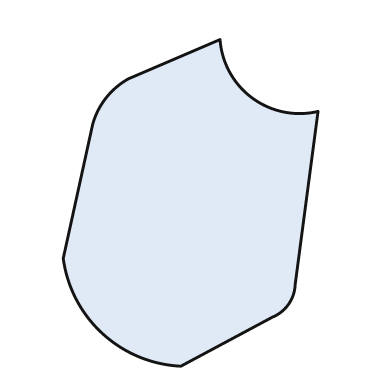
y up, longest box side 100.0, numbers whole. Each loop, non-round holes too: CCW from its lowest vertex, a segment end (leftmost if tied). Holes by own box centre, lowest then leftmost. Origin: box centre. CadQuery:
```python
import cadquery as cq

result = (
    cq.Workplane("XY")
    .moveTo(-3.0, -50.0)
    .lineTo(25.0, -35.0)
    .threePointArc((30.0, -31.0), (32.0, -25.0))
    .lineTo(39.0, 28.0)
    .threePointArc((19.0, 32.0), (9.0, 50.0))
    .lineTo(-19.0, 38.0)
    .threePointArc((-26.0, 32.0), (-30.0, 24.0))
    .lineTo(-39.0, -17.0)
    .threePointArc((-27.0, -40.0), (-3.0, -50.0))
    .close()
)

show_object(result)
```